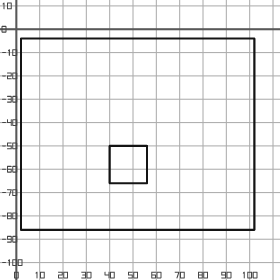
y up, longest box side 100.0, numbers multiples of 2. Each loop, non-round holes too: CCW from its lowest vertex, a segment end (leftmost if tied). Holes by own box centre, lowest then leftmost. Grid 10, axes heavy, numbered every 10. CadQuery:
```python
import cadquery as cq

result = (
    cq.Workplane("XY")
    .moveTo(2.0, -86.0)
    .lineTo(102.0, -86.0)
    .lineTo(102.0, -4.0)
    .lineTo(2.0, -4.0)
    .close()
    .moveTo(40.0, -66.0)
    .lineTo(56.0, -66.0)
    .lineTo(56.0, -50.0)
    .lineTo(40.0, -50.0)
    .close()
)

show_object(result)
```